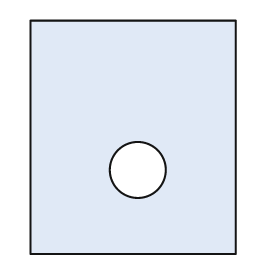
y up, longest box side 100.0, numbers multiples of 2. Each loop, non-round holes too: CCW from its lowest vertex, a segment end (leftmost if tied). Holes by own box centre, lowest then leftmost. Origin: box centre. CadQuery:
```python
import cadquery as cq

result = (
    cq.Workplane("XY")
    .moveTo(-44.0, -50.0)
    .lineTo(44.0, -50.0)
    .lineTo(44.0, 50.0)
    .lineTo(-44.0, 50.0)
    .close()
    .moveTo(2.0, -14.0)
    .circle(12.0)
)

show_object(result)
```